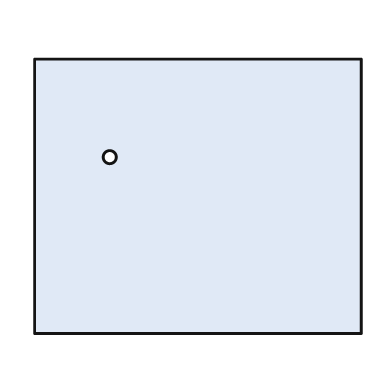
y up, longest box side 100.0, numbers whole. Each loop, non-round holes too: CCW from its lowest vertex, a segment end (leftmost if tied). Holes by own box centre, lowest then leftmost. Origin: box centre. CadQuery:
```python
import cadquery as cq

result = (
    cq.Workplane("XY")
    .moveTo(-50.0, -42.0)
    .lineTo(50.0, -42.0)
    .lineTo(50.0, 42.0)
    .lineTo(-50.0, 42.0)
    .close()
    .moveTo(-27.0, 12.0)
    .circle(2.0)
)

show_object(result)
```